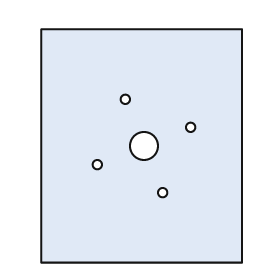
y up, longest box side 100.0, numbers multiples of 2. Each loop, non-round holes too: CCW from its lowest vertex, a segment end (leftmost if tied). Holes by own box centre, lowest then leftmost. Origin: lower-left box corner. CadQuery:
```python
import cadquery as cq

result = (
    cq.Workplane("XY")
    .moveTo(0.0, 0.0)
    .lineTo(86.0, 0.0)
    .lineTo(86.0, 100.0)
    .lineTo(0.0, 100.0)
    .close()
    .moveTo(52.0, 30.0)
    .circle(2.0)
    .moveTo(24.0, 42.0)
    .circle(2.0)
    .moveTo(44.0, 50.0)
    .circle(6.0)
    .moveTo(64.0, 58.0)
    .circle(2.0)
    .moveTo(36.0, 70.0)
    .circle(2.0)
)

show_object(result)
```